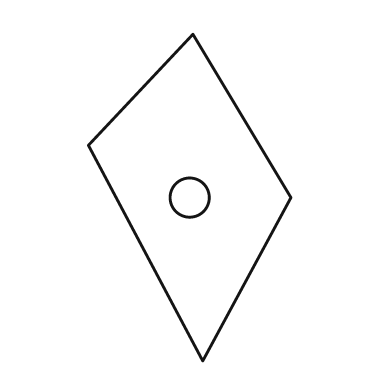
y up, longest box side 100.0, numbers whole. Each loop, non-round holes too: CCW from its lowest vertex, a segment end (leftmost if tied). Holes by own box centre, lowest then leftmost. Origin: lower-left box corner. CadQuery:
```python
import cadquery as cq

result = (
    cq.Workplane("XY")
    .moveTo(35.0, 0.0)
    .lineTo(62.0, 50.0)
    .lineTo(32.0, 100.0)
    .lineTo(0.0, 66.0)
    .close()
    .moveTo(31.0, 50.0)
    .circle(6.0)
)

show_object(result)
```